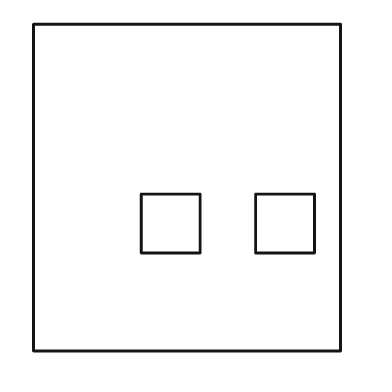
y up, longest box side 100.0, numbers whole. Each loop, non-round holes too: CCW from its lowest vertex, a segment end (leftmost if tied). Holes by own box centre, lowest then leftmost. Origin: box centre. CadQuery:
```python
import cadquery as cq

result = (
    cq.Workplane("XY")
    .moveTo(-47.0, -50.0)
    .lineTo(47.0, -50.0)
    .lineTo(47.0, 50.0)
    .lineTo(-47.0, 50.0)
    .close()
    .moveTo(-14.0, -20.0)
    .lineTo(4.0, -20.0)
    .lineTo(4.0, -2.0)
    .lineTo(-14.0, -2.0)
    .close()
    .moveTo(21.0, -20.0)
    .lineTo(39.0, -20.0)
    .lineTo(39.0, -2.0)
    .lineTo(21.0, -2.0)
    .close()
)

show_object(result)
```